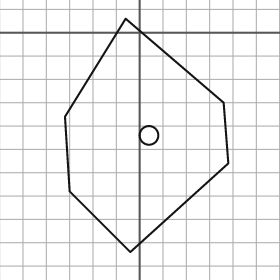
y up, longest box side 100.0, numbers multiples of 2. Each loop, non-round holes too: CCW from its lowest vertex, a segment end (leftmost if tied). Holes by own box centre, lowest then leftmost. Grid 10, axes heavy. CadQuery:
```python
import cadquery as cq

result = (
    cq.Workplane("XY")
    .moveTo(-4.0, -94.0)
    .lineTo(38.0, -56.0)
    .lineTo(36.0, -30.0)
    .lineTo(-6.0, 6.0)
    .lineTo(-32.0, -36.0)
    .lineTo(-30.0, -68.0)
    .close()
    .moveTo(4.0, -44.0)
    .circle(4.0)
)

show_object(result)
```